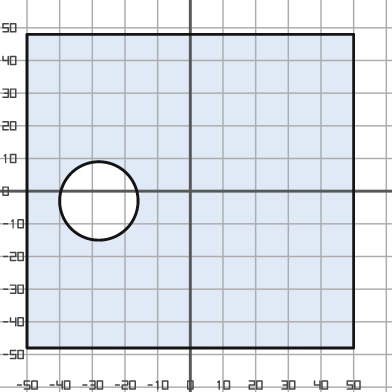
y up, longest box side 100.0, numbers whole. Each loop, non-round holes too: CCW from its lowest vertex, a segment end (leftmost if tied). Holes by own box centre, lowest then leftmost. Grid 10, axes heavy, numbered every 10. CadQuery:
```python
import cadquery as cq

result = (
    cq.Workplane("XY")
    .moveTo(-50.0, -48.0)
    .lineTo(50.0, -48.0)
    .lineTo(50.0, 48.0)
    .lineTo(-50.0, 48.0)
    .close()
    .moveTo(-28.0, -3.0)
    .circle(12.0)
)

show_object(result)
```